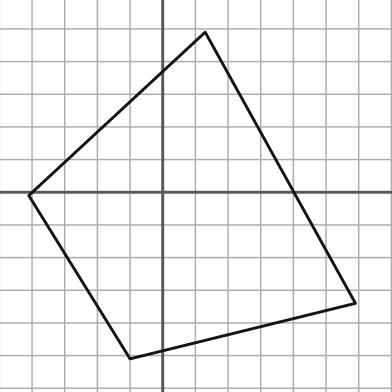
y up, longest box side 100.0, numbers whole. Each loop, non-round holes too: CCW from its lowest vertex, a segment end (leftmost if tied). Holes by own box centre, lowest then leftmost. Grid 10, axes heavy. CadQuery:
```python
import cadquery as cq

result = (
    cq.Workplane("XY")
    .moveTo(-10.0, -51.0)
    .lineTo(59.0, -34.0)
    .lineTo(13.0, 49.0)
    .lineTo(-41.0, -1.0)
    .close()
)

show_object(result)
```